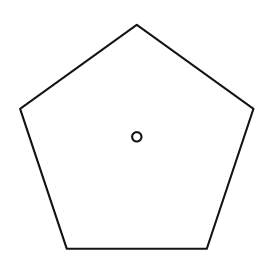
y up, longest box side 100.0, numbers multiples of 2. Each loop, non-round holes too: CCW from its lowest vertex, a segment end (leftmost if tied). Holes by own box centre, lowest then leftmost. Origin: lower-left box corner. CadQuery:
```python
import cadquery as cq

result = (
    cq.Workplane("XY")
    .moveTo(20.0, 0.0)
    .lineTo(80.0, 0.0)
    .lineTo(100.0, 60.0)
    .lineTo(50.0, 96.0)
    .lineTo(0.0, 60.0)
    .close()
    .moveTo(50.0, 48.0)
    .circle(2.0)
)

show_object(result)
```